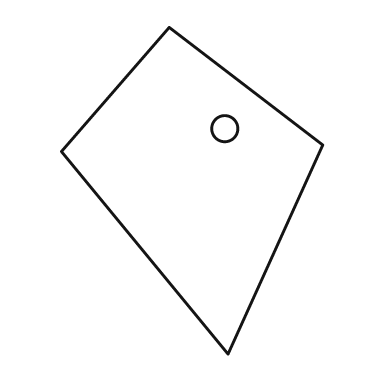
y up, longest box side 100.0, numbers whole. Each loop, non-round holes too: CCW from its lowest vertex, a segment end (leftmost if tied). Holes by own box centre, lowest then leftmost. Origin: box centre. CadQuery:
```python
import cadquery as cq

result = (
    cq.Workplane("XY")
    .moveTo(11.0, -50.0)
    .lineTo(40.0, 14.0)
    .lineTo(-7.0, 50.0)
    .lineTo(-40.0, 12.0)
    .close()
    .moveTo(10.0, 19.0)
    .circle(4.0)
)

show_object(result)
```